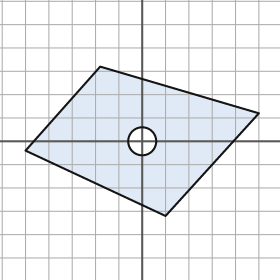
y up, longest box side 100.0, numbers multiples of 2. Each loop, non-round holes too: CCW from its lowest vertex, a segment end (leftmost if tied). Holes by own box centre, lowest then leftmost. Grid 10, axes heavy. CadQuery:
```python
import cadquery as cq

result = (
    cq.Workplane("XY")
    .moveTo(10.0, -32.0)
    .lineTo(50.0, 12.0)
    .lineTo(-18.0, 32.0)
    .lineTo(-50.0, -4.0)
    .close()
    .moveTo(0.0, 0.0)
    .circle(6.0)
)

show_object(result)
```